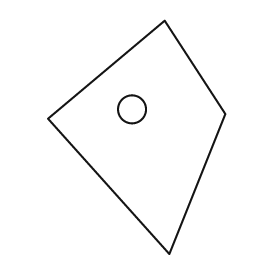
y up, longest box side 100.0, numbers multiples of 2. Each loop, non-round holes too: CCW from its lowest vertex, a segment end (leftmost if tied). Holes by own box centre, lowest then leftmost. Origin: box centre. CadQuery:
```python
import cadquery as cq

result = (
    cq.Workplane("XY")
    .moveTo(14.0, -50.0)
    .lineTo(38.0, 10.0)
    .lineTo(12.0, 50.0)
    .lineTo(-38.0, 8.0)
    .close()
    .moveTo(-2.0, 12.0)
    .circle(6.0)
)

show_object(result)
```